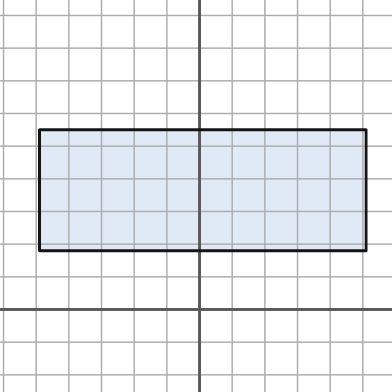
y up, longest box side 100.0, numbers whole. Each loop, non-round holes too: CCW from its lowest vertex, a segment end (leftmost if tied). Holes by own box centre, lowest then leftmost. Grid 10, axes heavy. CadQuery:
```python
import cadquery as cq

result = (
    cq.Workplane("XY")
    .moveTo(-49.0, 18.0)
    .lineTo(51.0, 18.0)
    .lineTo(51.0, 55.0)
    .lineTo(-49.0, 55.0)
    .close()
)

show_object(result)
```